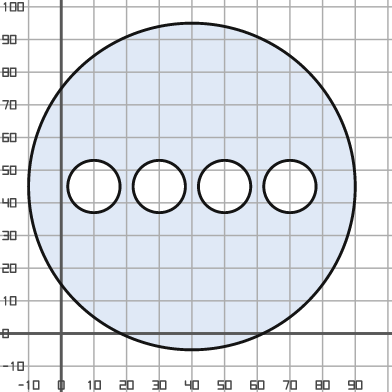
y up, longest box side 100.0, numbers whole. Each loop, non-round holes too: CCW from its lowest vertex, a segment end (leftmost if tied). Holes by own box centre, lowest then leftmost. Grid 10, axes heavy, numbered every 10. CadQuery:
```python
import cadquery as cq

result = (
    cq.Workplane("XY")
    .moveTo(40.0, 45.0)
    .circle(50.0)
    .moveTo(10.0, 45.0)
    .circle(8.0)
    .moveTo(30.0, 45.0)
    .circle(8.0)
    .moveTo(50.0, 45.0)
    .circle(8.0)
    .moveTo(70.0, 45.0)
    .circle(8.0)
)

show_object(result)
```